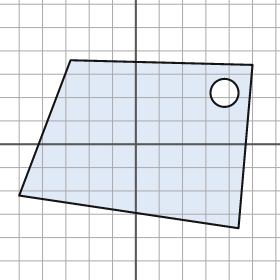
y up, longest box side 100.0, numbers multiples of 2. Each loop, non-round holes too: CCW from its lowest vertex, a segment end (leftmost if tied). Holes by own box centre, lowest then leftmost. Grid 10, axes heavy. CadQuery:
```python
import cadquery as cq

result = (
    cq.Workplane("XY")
    .moveTo(44.0, -36.0)
    .lineTo(50.0, 34.0)
    .lineTo(-28.0, 36.0)
    .lineTo(-50.0, -22.0)
    .close()
    .moveTo(38.0, 22.0)
    .circle(6.0)
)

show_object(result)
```